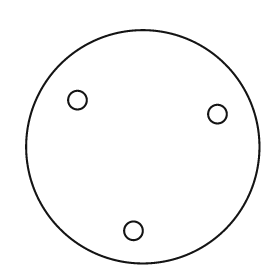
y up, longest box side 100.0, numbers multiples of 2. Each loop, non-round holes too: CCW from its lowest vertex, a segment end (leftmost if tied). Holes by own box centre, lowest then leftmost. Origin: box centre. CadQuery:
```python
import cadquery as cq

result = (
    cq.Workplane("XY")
    .moveTo(0.0, 0.0)
    .circle(50.0)
    .moveTo(-4.0, -36.0)
    .circle(4.0)
    .moveTo(32.0, 14.0)
    .circle(4.0)
    .moveTo(-28.0, 20.0)
    .circle(4.0)
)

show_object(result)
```